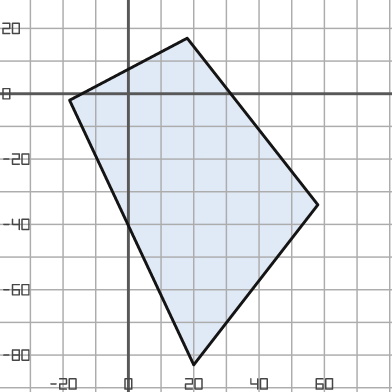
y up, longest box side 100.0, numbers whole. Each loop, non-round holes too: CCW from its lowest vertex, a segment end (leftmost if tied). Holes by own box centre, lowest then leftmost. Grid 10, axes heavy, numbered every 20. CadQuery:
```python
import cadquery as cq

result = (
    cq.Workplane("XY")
    .moveTo(20.0, -83.0)
    .lineTo(58.0, -34.0)
    .lineTo(18.0, 17.0)
    .lineTo(-18.0, -2.0)
    .close()
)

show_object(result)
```